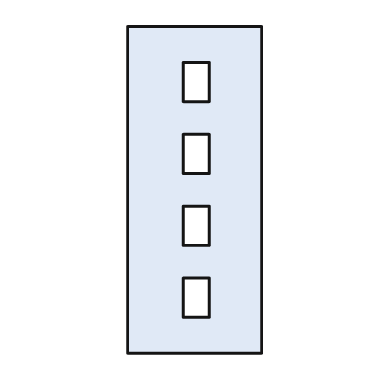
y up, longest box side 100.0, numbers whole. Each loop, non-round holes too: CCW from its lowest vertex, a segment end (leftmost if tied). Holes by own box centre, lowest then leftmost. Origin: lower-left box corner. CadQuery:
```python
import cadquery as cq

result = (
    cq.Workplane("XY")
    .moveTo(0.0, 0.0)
    .lineTo(41.0, 0.0)
    .lineTo(41.0, 100.0)
    .lineTo(0.0, 100.0)
    .close()
    .moveTo(17.0, 11.0)
    .lineTo(25.0, 11.0)
    .lineTo(25.0, 23.0)
    .lineTo(17.0, 23.0)
    .close()
    .moveTo(17.0, 33.0)
    .lineTo(25.0, 33.0)
    .lineTo(25.0, 45.0)
    .lineTo(17.0, 45.0)
    .close()
    .moveTo(17.0, 55.0)
    .lineTo(25.0, 55.0)
    .lineTo(25.0, 67.0)
    .lineTo(17.0, 67.0)
    .close()
    .moveTo(17.0, 77.0)
    .lineTo(25.0, 77.0)
    .lineTo(25.0, 89.0)
    .lineTo(17.0, 89.0)
    .close()
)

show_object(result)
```